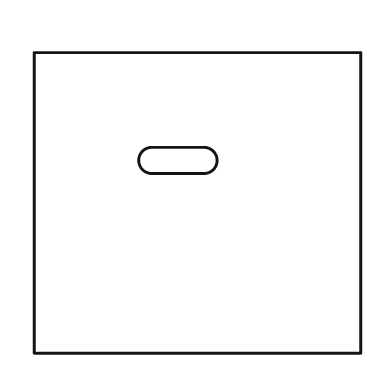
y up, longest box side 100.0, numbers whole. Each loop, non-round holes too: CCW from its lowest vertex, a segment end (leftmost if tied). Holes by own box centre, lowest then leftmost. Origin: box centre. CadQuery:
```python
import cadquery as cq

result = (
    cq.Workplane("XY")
    .moveTo(-50.0, -46.0)
    .lineTo(50.0, -46.0)
    .lineTo(50.0, 46.0)
    .lineTo(-50.0, 46.0)
    .close()
    .moveTo(-14.0, 9.0)
    .lineTo(2.0, 9.0)
    .threePointArc((6.0, 13.0), (2.0, 17.0))
    .lineTo(-14.0, 17.0)
    .threePointArc((-18.0, 13.0), (-14.0, 9.0))
    .close()
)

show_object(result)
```